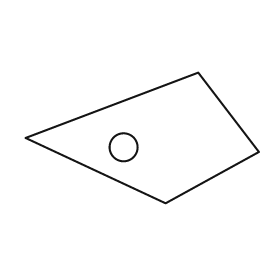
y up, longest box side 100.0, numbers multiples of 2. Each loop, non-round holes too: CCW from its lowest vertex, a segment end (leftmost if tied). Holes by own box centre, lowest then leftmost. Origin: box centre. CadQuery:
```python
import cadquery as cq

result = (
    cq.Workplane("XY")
    .moveTo(10.0, -28.0)
    .lineTo(50.0, -6.0)
    .lineTo(24.0, 28.0)
    .lineTo(-50.0, 0.0)
    .close()
    .moveTo(-8.0, -4.0)
    .circle(6.0)
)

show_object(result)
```